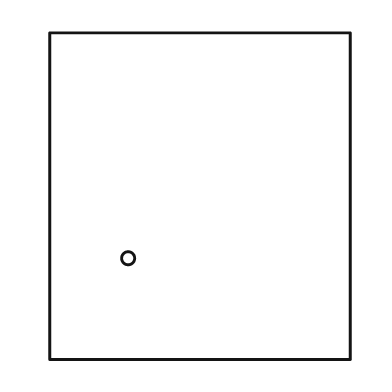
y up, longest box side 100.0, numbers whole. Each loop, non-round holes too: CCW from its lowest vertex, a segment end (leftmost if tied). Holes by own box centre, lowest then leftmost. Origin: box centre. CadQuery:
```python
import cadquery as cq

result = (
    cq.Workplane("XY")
    .moveTo(-46.0, -50.0)
    .lineTo(46.0, -50.0)
    .lineTo(46.0, 50.0)
    .lineTo(-46.0, 50.0)
    .close()
    .moveTo(-22.0, -19.0)
    .circle(2.0)
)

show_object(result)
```